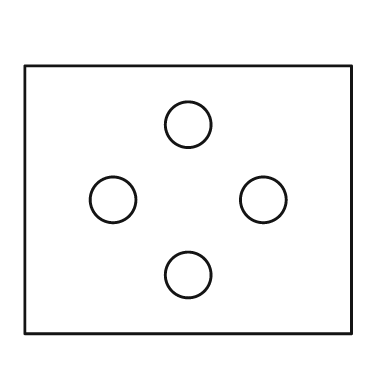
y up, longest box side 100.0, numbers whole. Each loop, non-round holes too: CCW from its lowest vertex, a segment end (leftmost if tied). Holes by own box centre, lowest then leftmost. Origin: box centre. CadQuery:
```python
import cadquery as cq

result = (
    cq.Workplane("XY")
    .moveTo(-50.0, -41.0)
    .lineTo(50.0, -41.0)
    .lineTo(50.0, 41.0)
    .lineTo(-50.0, 41.0)
    .close()
    .moveTo(0.0, -23.0)
    .circle(7.0)
    .moveTo(-23.0, 0.0)
    .circle(7.0)
    .moveTo(23.0, 0.0)
    .circle(7.0)
    .moveTo(0.0, 23.0)
    .circle(7.0)
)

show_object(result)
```